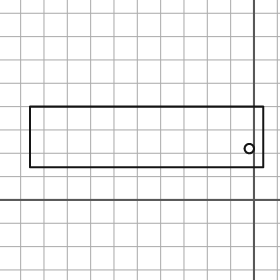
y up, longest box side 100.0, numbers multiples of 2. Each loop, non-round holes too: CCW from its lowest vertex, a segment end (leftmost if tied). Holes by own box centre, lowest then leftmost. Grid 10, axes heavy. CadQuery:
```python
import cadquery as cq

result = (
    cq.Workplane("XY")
    .moveTo(-96.0, 14.0)
    .lineTo(4.0, 14.0)
    .lineTo(4.0, 40.0)
    .lineTo(-96.0, 40.0)
    .close()
    .moveTo(-2.0, 22.0)
    .circle(2.0)
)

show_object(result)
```